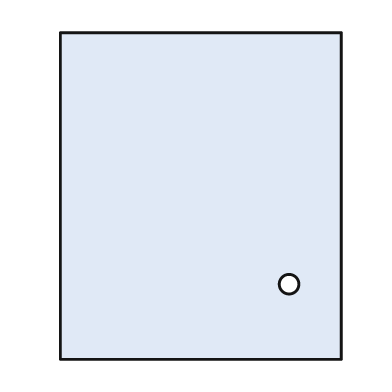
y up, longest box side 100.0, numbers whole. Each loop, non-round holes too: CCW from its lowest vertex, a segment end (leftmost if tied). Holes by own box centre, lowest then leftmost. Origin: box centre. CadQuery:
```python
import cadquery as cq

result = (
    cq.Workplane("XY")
    .moveTo(-43.0, -50.0)
    .lineTo(43.0, -50.0)
    .lineTo(43.0, 50.0)
    .lineTo(-43.0, 50.0)
    .close()
    .moveTo(27.0, -27.0)
    .circle(3.0)
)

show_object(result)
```